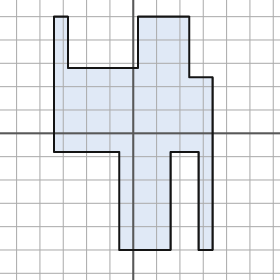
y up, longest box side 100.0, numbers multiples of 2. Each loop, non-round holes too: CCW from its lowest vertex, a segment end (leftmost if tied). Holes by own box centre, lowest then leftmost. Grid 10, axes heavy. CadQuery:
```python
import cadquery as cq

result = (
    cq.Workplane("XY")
    .moveTo(-6.0, -50.0)
    .lineTo(16.0, -50.0)
    .lineTo(16.0, -8.0)
    .lineTo(28.0, -8.0)
    .lineTo(28.0, -50.0)
    .lineTo(34.0, -50.0)
    .lineTo(34.0, 24.0)
    .lineTo(24.0, 24.0)
    .lineTo(24.0, 50.0)
    .lineTo(2.0, 50.0)
    .lineTo(2.0, 28.0)
    .lineTo(-28.0, 28.0)
    .lineTo(-28.0, 50.0)
    .lineTo(-34.0, 50.0)
    .lineTo(-34.0, -8.0)
    .lineTo(-6.0, -8.0)
    .close()
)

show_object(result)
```